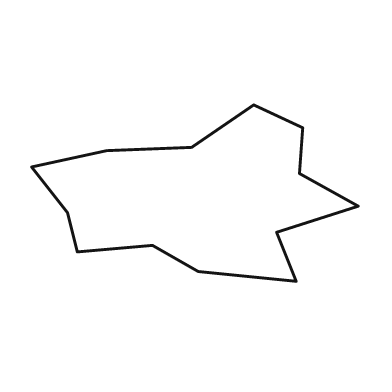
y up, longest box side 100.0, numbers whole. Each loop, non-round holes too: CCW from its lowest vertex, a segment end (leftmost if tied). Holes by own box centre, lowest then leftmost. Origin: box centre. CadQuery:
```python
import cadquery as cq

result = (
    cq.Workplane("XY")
    .moveTo(31.0, -27.0)
    .lineTo(25.0, -12.0)
    .lineTo(50.0, -4.0)
    .lineTo(32.0, 6.0)
    .lineTo(33.0, 20.0)
    .lineTo(18.0, 27.0)
    .lineTo(-1.0, 14.0)
    .lineTo(-27.0, 13.0)
    .lineTo(-50.0, 8.0)
    .lineTo(-39.0, -6.0)
    .lineTo(-36.0, -18.0)
    .lineTo(-13.0, -16.0)
    .lineTo(1.0, -24.0)
    .close()
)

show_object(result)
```